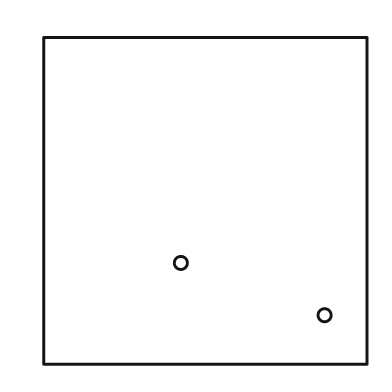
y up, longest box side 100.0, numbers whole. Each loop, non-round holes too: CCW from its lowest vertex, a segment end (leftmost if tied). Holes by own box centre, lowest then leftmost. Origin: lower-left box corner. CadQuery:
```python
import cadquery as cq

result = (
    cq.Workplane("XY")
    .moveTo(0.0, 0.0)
    .lineTo(99.0, 0.0)
    .lineTo(99.0, 100.0)
    .lineTo(0.0, 100.0)
    .close()
    .moveTo(86.0, 15.0)
    .circle(2.0)
    .moveTo(42.0, 31.0)
    .circle(2.0)
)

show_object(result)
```